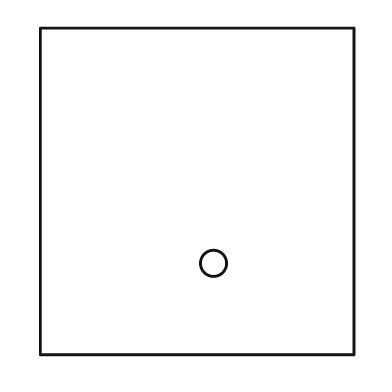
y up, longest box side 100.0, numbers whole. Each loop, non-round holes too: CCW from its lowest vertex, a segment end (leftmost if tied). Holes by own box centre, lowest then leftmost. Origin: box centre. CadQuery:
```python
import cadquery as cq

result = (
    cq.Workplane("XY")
    .moveTo(-48.0, -50.0)
    .lineTo(48.0, -50.0)
    .lineTo(48.0, 50.0)
    .lineTo(-48.0, 50.0)
    .close()
    .moveTo(5.0, -22.0)
    .circle(4.0)
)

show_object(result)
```